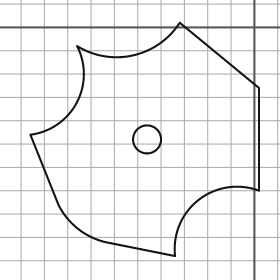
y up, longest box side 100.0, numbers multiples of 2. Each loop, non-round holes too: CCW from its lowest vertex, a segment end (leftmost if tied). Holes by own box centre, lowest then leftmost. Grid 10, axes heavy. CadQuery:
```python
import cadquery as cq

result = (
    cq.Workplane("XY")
    .moveTo(-34.0, -98.0)
    .threePointArc((-24.0, -74.0), (2.0, -70.0))
    .lineTo(2.0, -26.0)
    .lineTo(-32.0, 2.0)
    .threePointArc((-52.0, -12.0), (-76.0, -8.0))
    .threePointArc((-76.0, -32.0), (-96.0, -46.0))
    .lineTo(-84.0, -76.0)
    .threePointArc((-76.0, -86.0), (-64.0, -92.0))
    .close()
    .moveTo(-46.0, -48.0)
    .circle(6.0)
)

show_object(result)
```